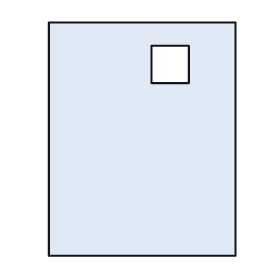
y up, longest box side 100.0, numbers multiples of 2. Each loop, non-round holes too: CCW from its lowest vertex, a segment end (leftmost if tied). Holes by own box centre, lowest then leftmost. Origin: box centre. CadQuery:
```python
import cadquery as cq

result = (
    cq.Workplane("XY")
    .moveTo(-40.0, -50.0)
    .lineTo(40.0, -50.0)
    .lineTo(40.0, 50.0)
    .lineTo(-40.0, 50.0)
    .close()
    .moveTo(4.0, 24.0)
    .lineTo(20.0, 24.0)
    .lineTo(20.0, 40.0)
    .lineTo(4.0, 40.0)
    .close()
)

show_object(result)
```